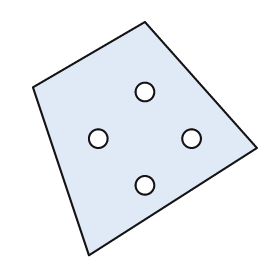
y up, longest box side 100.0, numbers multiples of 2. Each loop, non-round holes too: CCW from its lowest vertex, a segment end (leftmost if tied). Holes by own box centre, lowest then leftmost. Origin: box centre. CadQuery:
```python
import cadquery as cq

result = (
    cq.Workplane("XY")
    .moveTo(-24.0, -50.0)
    .lineTo(48.0, -4.0)
    .lineTo(0.0, 50.0)
    .lineTo(-48.0, 22.0)
    .close()
    .moveTo(0.0, -20.0)
    .circle(4.0)
    .moveTo(-20.0, 0.0)
    .circle(4.0)
    .moveTo(20.0, 0.0)
    .circle(4.0)
    .moveTo(0.0, 20.0)
    .circle(4.0)
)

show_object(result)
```